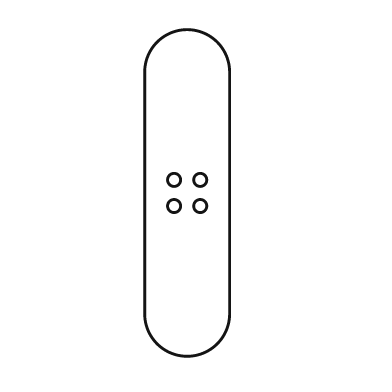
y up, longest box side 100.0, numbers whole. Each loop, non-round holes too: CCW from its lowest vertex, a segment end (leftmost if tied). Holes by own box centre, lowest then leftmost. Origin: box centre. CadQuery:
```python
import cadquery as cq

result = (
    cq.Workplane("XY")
    .moveTo(-13.0, -37.0)
    .threePointArc((0.0, -50.0), (13.0, -37.0))
    .lineTo(13.0, 37.0)
    .threePointArc((0.0, 50.0), (-13.0, 37.0))
    .close()
    .moveTo(-4.0, -4.0)
    .circle(2.0)
    .moveTo(4.0, -4.0)
    .circle(2.0)
    .moveTo(-4.0, 4.0)
    .circle(2.0)
    .moveTo(4.0, 4.0)
    .circle(2.0)
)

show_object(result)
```